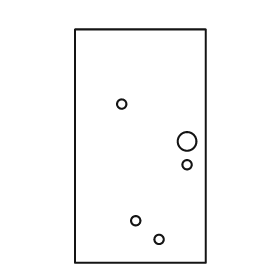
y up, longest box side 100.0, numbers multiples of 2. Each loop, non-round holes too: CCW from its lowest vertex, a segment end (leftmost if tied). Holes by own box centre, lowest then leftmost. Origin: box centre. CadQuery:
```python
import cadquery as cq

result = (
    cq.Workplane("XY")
    .moveTo(-28.0, -50.0)
    .lineTo(28.0, -50.0)
    .lineTo(28.0, 50.0)
    .lineTo(-28.0, 50.0)
    .close()
    .moveTo(8.0, -40.0)
    .circle(2.0)
    .moveTo(-2.0, -32.0)
    .circle(2.0)
    .moveTo(20.0, -8.0)
    .circle(2.0)
    .moveTo(20.0, 2.0)
    .circle(4.0)
    .moveTo(-8.0, 18.0)
    .circle(2.0)
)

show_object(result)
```